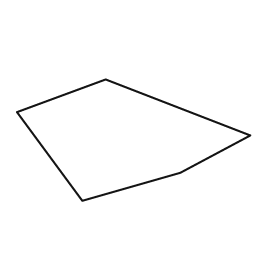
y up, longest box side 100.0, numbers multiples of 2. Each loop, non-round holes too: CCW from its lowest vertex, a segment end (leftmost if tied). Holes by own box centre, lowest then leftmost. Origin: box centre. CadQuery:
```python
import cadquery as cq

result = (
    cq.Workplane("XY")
    .moveTo(-22.0, -26.0)
    .lineTo(20.0, -14.0)
    .lineTo(50.0, 2.0)
    .lineTo(-12.0, 26.0)
    .lineTo(-50.0, 12.0)
    .close()
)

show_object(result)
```